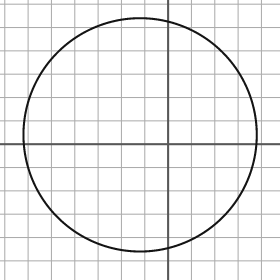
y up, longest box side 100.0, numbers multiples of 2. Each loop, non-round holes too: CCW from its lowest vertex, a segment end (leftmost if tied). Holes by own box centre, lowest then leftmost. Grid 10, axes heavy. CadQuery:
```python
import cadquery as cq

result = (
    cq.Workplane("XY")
    .moveTo(-12.0, 4.0)
    .circle(50.0)
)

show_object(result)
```